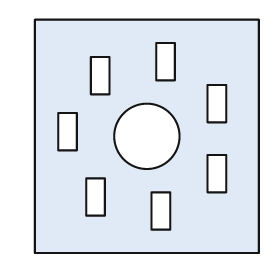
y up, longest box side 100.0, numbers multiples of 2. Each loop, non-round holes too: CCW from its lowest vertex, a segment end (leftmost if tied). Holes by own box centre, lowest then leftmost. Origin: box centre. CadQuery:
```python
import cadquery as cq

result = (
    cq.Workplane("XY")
    .moveTo(-48.0, -50.0)
    .lineTo(48.0, -50.0)
    .lineTo(48.0, 50.0)
    .lineTo(-48.0, 50.0)
    .close()
    .moveTo(2.0, -40.0)
    .lineTo(10.0, -40.0)
    .lineTo(10.0, -24.0)
    .lineTo(2.0, -24.0)
    .close()
    .moveTo(-26.0, -34.0)
    .lineTo(-18.0, -34.0)
    .lineTo(-18.0, -18.0)
    .lineTo(-26.0, -18.0)
    .close()
    .moveTo(26.0, -24.0)
    .lineTo(34.0, -24.0)
    .lineTo(34.0, -8.0)
    .lineTo(26.0, -8.0)
    .close()
    .moveTo(0.0, 0.0)
    .circle(14.0)
    .moveTo(-38.0, -6.0)
    .lineTo(-30.0, -6.0)
    .lineTo(-30.0, 10.0)
    .lineTo(-38.0, 10.0)
    .close()
    .moveTo(26.0, 6.0)
    .lineTo(34.0, 6.0)
    .lineTo(34.0, 22.0)
    .lineTo(26.0, 22.0)
    .close()
    .moveTo(-24.0, 18.0)
    .lineTo(-16.0, 18.0)
    .lineTo(-16.0, 34.0)
    .lineTo(-24.0, 34.0)
    .close()
    .moveTo(4.0, 24.0)
    .lineTo(12.0, 24.0)
    .lineTo(12.0, 40.0)
    .lineTo(4.0, 40.0)
    .close()
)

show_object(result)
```